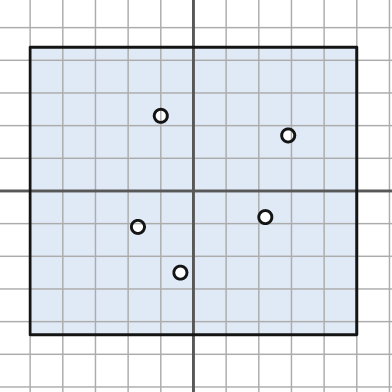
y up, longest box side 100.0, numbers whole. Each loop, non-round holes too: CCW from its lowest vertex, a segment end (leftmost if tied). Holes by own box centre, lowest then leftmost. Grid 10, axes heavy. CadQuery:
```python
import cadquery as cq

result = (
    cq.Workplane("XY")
    .moveTo(-50.0, -44.0)
    .lineTo(50.0, -44.0)
    .lineTo(50.0, 44.0)
    .lineTo(-50.0, 44.0)
    .close()
    .moveTo(-4.0, -25.0)
    .circle(2.0)
    .moveTo(-17.0, -11.0)
    .circle(2.0)
    .moveTo(22.0, -8.0)
    .circle(2.0)
    .moveTo(29.0, 17.0)
    .circle(2.0)
    .moveTo(-10.0, 23.0)
    .circle(2.0)
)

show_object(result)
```